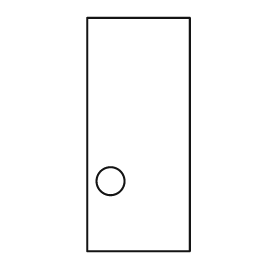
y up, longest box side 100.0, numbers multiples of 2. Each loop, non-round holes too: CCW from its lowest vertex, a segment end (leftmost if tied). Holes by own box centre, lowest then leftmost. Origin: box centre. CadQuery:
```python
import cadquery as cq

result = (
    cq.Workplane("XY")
    .moveTo(-22.0, -50.0)
    .lineTo(22.0, -50.0)
    .lineTo(22.0, 50.0)
    .lineTo(-22.0, 50.0)
    .close()
    .moveTo(-12.0, -20.0)
    .circle(6.0)
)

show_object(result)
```